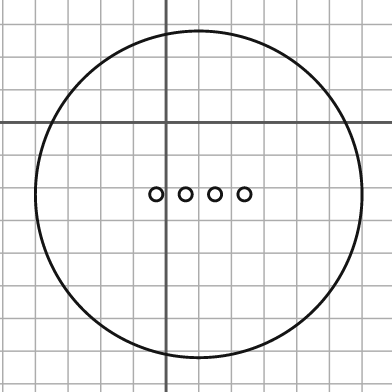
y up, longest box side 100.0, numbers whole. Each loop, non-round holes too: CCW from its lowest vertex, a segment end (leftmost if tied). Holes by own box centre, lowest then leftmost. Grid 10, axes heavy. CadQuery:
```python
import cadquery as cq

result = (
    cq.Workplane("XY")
    .moveTo(10.0, -22.0)
    .circle(50.0)
    .moveTo(-3.0, -22.0)
    .circle(2.0)
    .moveTo(6.0, -22.0)
    .circle(2.0)
    .moveTo(15.0, -22.0)
    .circle(2.0)
    .moveTo(24.0, -22.0)
    .circle(2.0)
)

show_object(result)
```